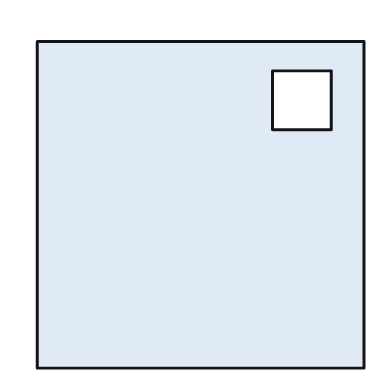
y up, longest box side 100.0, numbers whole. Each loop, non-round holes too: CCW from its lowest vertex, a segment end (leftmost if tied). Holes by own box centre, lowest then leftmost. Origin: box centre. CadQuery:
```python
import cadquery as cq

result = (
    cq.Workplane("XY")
    .moveTo(-50.0, -50.0)
    .lineTo(50.0, -50.0)
    .lineTo(50.0, 50.0)
    .lineTo(-50.0, 50.0)
    .close()
    .moveTo(22.0, 23.0)
    .lineTo(40.0, 23.0)
    .lineTo(40.0, 41.0)
    .lineTo(22.0, 41.0)
    .close()
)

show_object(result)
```